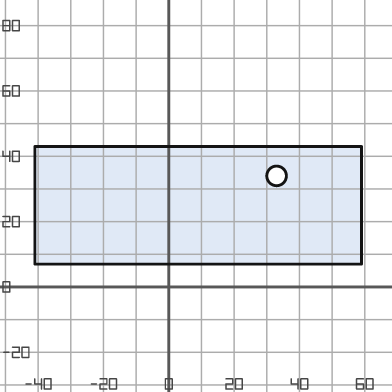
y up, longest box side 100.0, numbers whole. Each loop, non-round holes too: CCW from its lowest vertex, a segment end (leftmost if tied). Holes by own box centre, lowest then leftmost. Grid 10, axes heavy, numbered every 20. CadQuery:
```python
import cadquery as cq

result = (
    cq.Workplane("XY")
    .moveTo(-41.0, 7.0)
    .lineTo(59.0, 7.0)
    .lineTo(59.0, 43.0)
    .lineTo(-41.0, 43.0)
    .close()
    .moveTo(33.0, 34.0)
    .circle(3.0)
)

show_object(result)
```